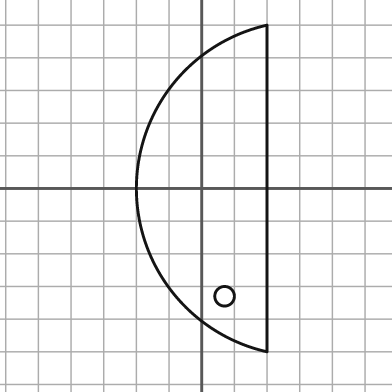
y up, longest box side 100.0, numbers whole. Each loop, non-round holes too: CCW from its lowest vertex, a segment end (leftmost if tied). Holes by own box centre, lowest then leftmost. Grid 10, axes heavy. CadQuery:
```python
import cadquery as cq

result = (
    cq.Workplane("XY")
    .moveTo(20.0, -50.0)
    .lineTo(20.0, 50.0)
    .threePointArc((-20.0, 0.0), (20.0, -50.0))
    .close()
    .moveTo(7.0, -33.0)
    .circle(3.0)
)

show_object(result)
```